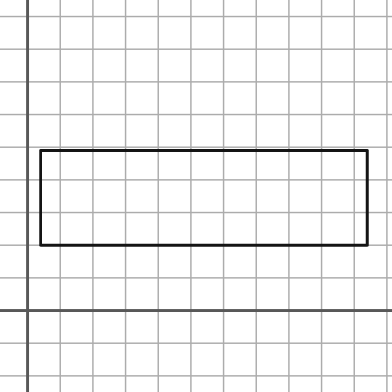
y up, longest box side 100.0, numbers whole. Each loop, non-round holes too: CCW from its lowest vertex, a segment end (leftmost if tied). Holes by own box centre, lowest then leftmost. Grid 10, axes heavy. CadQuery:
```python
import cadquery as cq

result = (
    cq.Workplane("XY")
    .moveTo(4.0, 20.0)
    .lineTo(104.0, 20.0)
    .lineTo(104.0, 49.0)
    .lineTo(4.0, 49.0)
    .close()
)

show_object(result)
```